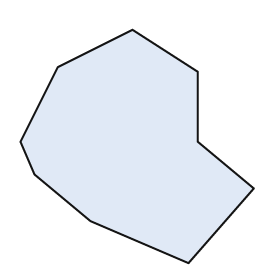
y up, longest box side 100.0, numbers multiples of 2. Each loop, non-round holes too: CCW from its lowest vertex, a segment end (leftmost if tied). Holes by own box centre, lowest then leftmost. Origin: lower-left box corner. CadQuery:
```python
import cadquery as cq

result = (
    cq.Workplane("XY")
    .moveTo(72.0, 0.0)
    .lineTo(100.0, 32.0)
    .lineTo(76.0, 52.0)
    .lineTo(76.0, 82.0)
    .lineTo(48.0, 100.0)
    .lineTo(16.0, 84.0)
    .lineTo(0.0, 52.0)
    .lineTo(6.0, 38.0)
    .lineTo(30.0, 18.0)
    .close()
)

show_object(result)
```